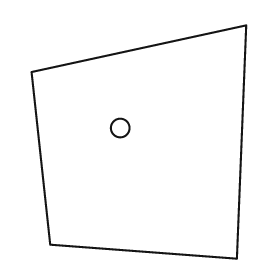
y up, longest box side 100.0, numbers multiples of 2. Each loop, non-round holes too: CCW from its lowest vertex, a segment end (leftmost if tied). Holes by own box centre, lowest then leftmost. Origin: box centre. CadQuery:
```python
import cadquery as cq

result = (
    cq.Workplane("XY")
    .moveTo(42.0, -50.0)
    .lineTo(46.0, 50.0)
    .lineTo(-46.0, 30.0)
    .lineTo(-38.0, -44.0)
    .close()
    .moveTo(-8.0, 6.0)
    .circle(4.0)
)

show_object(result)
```